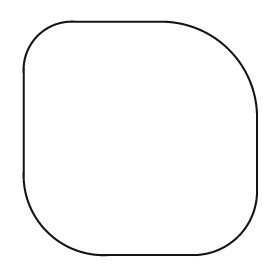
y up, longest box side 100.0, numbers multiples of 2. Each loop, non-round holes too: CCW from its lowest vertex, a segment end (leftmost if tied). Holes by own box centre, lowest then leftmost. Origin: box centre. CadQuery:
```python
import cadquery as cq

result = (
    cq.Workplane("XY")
    .moveTo(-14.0, -50.0)
    .lineTo(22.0, -50.0)
    .threePointArc((42.0, -42.0), (50.0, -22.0))
    .lineTo(50.0, 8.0)
    .threePointArc((38.0, 38.0), (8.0, 50.0))
    .lineTo(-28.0, 50.0)
    .threePointArc((-44.0, 44.0), (-50.0, 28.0))
    .lineTo(-50.0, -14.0)
    .threePointArc((-40.0, -40.0), (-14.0, -50.0))
    .close()
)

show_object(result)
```